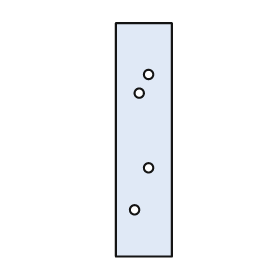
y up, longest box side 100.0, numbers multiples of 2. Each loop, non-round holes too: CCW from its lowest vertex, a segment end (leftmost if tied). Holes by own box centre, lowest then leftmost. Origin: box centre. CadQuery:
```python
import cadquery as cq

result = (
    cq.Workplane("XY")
    .moveTo(-12.0, -50.0)
    .lineTo(12.0, -50.0)
    .lineTo(12.0, 50.0)
    .lineTo(-12.0, 50.0)
    .close()
    .moveTo(-4.0, -30.0)
    .circle(2.0)
    .moveTo(2.0, -12.0)
    .circle(2.0)
    .moveTo(-2.0, 20.0)
    .circle(2.0)
    .moveTo(2.0, 28.0)
    .circle(2.0)
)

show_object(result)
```